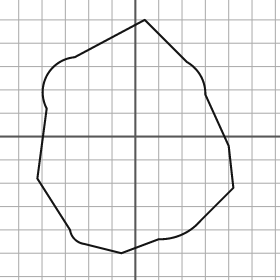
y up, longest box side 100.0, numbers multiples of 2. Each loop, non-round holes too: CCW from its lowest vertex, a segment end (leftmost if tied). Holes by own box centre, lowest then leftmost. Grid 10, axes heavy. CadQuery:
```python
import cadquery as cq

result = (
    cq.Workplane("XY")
    .moveTo(-6.0, -50.0)
    .lineTo(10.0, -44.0)
    .threePointArc((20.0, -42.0), (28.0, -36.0))
    .lineTo(42.0, -22.0)
    .lineTo(40.0, -4.0)
    .lineTo(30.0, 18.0)
    .threePointArc((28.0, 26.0), (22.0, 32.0))
    .lineTo(4.0, 50.0)
    .lineTo(-26.0, 34.0)
    .threePointArc((-38.0, 26.0), (-38.0, 12.0))
    .lineTo(-42.0, -18.0)
    .lineTo(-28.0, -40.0)
    .threePointArc((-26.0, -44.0), (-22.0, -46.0))
    .close()
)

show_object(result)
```